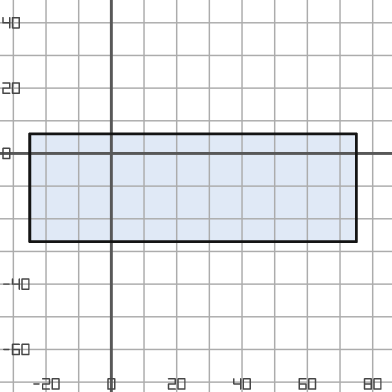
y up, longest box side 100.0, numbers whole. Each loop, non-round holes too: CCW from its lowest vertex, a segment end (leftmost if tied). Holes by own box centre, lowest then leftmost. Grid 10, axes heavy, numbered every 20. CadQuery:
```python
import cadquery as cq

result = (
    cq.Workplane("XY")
    .moveTo(-25.0, -27.0)
    .lineTo(75.0, -27.0)
    .lineTo(75.0, 6.0)
    .lineTo(-25.0, 6.0)
    .close()
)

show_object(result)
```